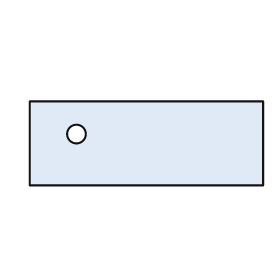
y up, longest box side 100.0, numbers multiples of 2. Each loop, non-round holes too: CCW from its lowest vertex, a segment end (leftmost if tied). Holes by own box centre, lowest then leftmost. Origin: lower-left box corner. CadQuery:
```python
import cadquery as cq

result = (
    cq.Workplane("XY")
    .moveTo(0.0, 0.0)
    .lineTo(100.0, 0.0)
    .lineTo(100.0, 36.0)
    .lineTo(0.0, 36.0)
    .close()
    .moveTo(20.0, 22.0)
    .circle(4.0)
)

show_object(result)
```